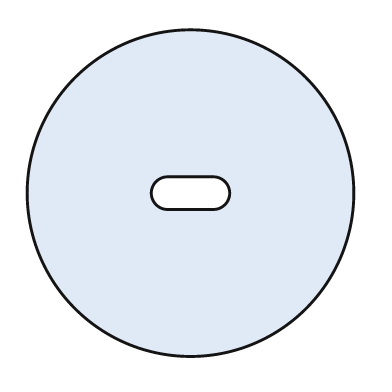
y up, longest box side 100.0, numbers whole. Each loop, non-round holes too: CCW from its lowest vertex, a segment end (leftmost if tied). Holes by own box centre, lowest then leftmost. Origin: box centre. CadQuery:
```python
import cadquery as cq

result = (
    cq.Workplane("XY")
    .moveTo(0.0, 0.0)
    .circle(50.0)
    .moveTo(-7.0, -5.0)
    .lineTo(7.0, -5.0)
    .threePointArc((12.0, 0.0), (7.0, 5.0))
    .lineTo(-7.0, 5.0)
    .threePointArc((-12.0, 0.0), (-7.0, -5.0))
    .close()
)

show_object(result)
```